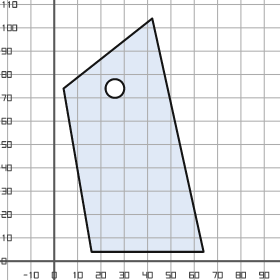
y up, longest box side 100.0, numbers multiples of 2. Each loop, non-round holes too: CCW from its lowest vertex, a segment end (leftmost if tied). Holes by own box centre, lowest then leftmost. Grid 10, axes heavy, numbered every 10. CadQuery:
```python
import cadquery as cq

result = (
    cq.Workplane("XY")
    .moveTo(16.0, 4.0)
    .lineTo(64.0, 4.0)
    .lineTo(42.0, 104.0)
    .lineTo(4.0, 74.0)
    .close()
    .moveTo(26.0, 74.0)
    .circle(4.0)
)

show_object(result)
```